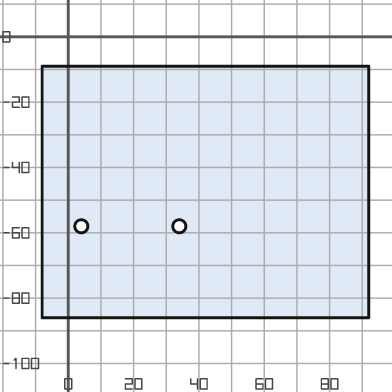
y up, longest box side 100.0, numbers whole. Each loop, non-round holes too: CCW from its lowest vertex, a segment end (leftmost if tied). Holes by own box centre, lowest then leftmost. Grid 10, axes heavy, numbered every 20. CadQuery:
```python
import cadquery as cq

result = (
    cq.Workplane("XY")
    .moveTo(-8.0, -86.0)
    .lineTo(92.0, -86.0)
    .lineTo(92.0, -9.0)
    .lineTo(-8.0, -9.0)
    .close()
    .moveTo(4.0, -58.0)
    .circle(2.0)
    .moveTo(34.0, -58.0)
    .circle(2.0)
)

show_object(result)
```